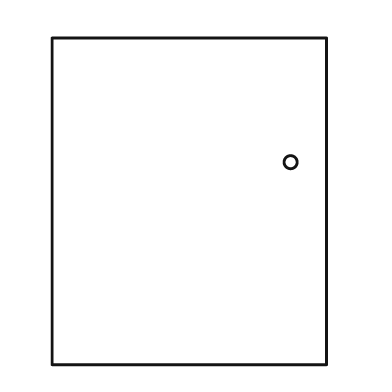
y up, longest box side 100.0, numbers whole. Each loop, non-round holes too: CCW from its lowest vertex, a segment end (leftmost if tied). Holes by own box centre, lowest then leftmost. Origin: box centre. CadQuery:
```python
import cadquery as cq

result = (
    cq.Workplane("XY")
    .moveTo(-42.0, -50.0)
    .lineTo(42.0, -50.0)
    .lineTo(42.0, 50.0)
    .lineTo(-42.0, 50.0)
    .close()
    .moveTo(31.0, 12.0)
    .circle(2.0)
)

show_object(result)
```